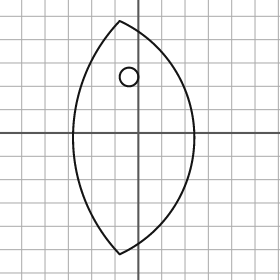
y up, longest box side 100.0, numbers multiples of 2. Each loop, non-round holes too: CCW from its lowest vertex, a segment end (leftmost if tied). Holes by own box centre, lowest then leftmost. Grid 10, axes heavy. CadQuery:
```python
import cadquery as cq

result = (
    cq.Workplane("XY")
    .moveTo(-8.0, -52.0)
    .threePointArc((24.0, -2.0), (-8.0, 48.0))
    .threePointArc((-28.0, -2.0), (-8.0, -52.0))
    .close()
    .moveTo(-4.0, 24.0)
    .circle(4.0)
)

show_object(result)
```